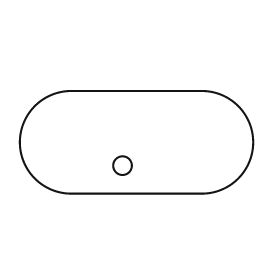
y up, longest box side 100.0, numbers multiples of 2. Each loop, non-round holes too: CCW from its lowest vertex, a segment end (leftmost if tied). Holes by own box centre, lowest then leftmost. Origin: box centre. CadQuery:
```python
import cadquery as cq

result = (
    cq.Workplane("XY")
    .moveTo(-28.0, -22.0)
    .lineTo(28.0, -22.0)
    .threePointArc((50.0, 0.0), (28.0, 22.0))
    .lineTo(-28.0, 22.0)
    .threePointArc((-50.0, 0.0), (-28.0, -22.0))
    .close()
    .moveTo(-6.0, -10.0)
    .circle(4.0)
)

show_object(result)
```